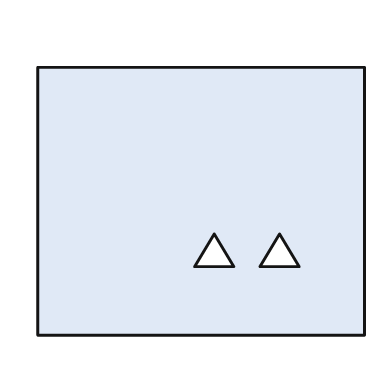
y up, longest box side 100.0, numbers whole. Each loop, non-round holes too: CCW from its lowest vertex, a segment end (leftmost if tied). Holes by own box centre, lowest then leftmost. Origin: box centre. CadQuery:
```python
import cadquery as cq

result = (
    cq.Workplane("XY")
    .moveTo(-50.0, -41.0)
    .lineTo(50.0, -41.0)
    .lineTo(50.0, 41.0)
    .lineTo(-50.0, 41.0)
    .close()
    .moveTo(-2.0, -20.0)
    .lineTo(10.0, -20.0)
    .lineTo(4.0, -10.0)
    .close()
    .moveTo(18.0, -20.0)
    .lineTo(30.0, -20.0)
    .lineTo(24.0, -10.0)
    .close()
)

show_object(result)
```